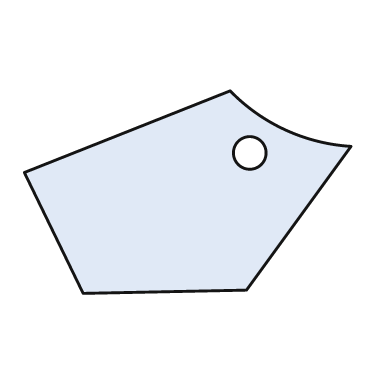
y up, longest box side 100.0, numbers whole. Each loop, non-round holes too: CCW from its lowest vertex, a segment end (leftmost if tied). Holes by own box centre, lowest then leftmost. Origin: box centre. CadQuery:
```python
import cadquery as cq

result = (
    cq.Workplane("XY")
    .moveTo(-32.0, -31.0)
    .lineTo(18.0, -30.0)
    .lineTo(50.0, 14.0)
    .threePointArc((30.0, 19.0), (13.0, 31.0))
    .lineTo(-50.0, 6.0)
    .close()
    .moveTo(19.0, 12.0)
    .circle(5.0)
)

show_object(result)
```